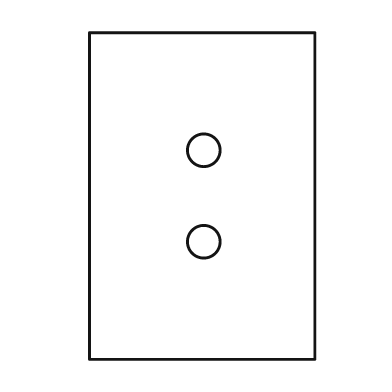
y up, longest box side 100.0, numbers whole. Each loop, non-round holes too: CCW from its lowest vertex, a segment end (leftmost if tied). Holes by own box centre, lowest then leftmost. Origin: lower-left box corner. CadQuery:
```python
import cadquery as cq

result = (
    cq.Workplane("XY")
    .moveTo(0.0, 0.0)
    .lineTo(69.0, 0.0)
    .lineTo(69.0, 100.0)
    .lineTo(0.0, 100.0)
    .close()
    .moveTo(35.0, 36.0)
    .circle(5.0)
    .moveTo(35.0, 64.0)
    .circle(5.0)
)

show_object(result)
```